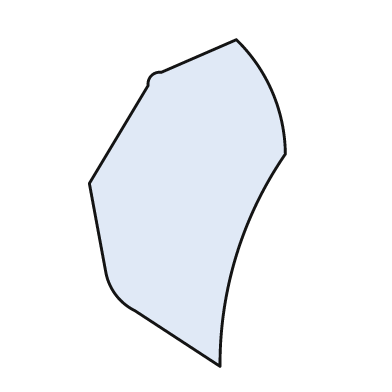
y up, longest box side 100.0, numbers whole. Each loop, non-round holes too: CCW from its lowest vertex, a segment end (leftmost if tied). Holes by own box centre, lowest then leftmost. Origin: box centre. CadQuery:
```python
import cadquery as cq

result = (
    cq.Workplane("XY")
    .moveTo(10.0, -50.0)
    .threePointArc((15.0, -16.0), (30.0, 15.0))
    .threePointArc((26.0, 34.0), (15.0, 50.0))
    .lineTo(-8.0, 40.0)
    .threePointArc((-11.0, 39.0), (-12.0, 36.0))
    .lineTo(-30.0, 6.0)
    .lineTo(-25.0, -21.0)
    .threePointArc((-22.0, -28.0), (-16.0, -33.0))
    .close()
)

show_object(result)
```